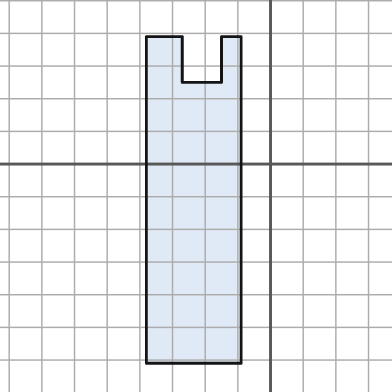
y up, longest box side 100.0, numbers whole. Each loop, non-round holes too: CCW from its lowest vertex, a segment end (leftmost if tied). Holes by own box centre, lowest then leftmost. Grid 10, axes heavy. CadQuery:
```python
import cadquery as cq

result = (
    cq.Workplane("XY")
    .moveTo(-38.0, -61.0)
    .lineTo(-9.0, -61.0)
    .lineTo(-9.0, 39.0)
    .lineTo(-15.0, 39.0)
    .lineTo(-15.0, 25.0)
    .lineTo(-27.0, 25.0)
    .lineTo(-27.0, 39.0)
    .lineTo(-38.0, 39.0)
    .close()
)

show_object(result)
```